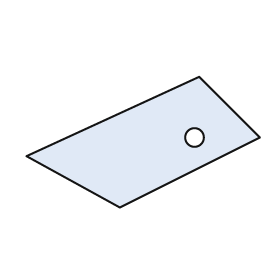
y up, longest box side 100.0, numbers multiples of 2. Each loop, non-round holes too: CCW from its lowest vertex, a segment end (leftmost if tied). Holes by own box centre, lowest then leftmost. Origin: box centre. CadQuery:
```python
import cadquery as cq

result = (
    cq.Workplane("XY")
    .moveTo(-10.0, -28.0)
    .lineTo(50.0, 2.0)
    .lineTo(24.0, 28.0)
    .lineTo(-50.0, -6.0)
    .close()
    .moveTo(22.0, 2.0)
    .circle(4.0)
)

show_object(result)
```